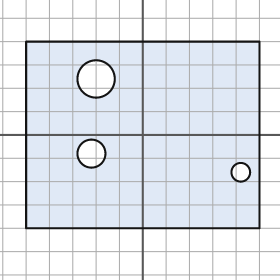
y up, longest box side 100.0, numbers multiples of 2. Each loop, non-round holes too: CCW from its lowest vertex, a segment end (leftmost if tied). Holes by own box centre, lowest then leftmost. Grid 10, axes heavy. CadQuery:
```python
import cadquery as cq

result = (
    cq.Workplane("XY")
    .moveTo(-50.0, -40.0)
    .lineTo(50.0, -40.0)
    .lineTo(50.0, 40.0)
    .lineTo(-50.0, 40.0)
    .close()
    .moveTo(42.0, -16.0)
    .circle(4.0)
    .moveTo(-22.0, -8.0)
    .circle(6.0)
    .moveTo(-20.0, 24.0)
    .circle(8.0)
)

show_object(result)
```